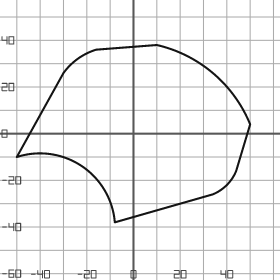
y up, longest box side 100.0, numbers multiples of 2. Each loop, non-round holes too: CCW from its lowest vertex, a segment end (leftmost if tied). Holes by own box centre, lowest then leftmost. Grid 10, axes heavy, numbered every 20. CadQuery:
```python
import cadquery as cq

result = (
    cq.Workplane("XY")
    .moveTo(-8.0, -38.0)
    .lineTo(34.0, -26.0)
    .threePointArc((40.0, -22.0), (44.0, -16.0))
    .lineTo(50.0, 4.0)
    .threePointArc((34.0, 26.0), (10.0, 38.0))
    .lineTo(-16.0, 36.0)
    .threePointArc((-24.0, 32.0), (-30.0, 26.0))
    .lineTo(-50.0, -10.0)
    .threePointArc((-22.0, -14.0), (-8.0, -38.0))
    .close()
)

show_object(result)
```